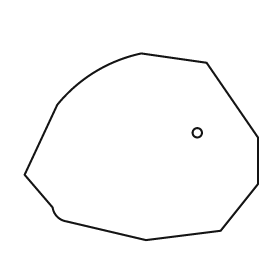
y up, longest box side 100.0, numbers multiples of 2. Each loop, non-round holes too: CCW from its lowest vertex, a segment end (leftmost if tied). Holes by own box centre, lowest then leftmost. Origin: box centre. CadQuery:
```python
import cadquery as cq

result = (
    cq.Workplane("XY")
    .moveTo(2.0, -40.0)
    .lineTo(34.0, -36.0)
    .lineTo(50.0, -16.0)
    .lineTo(50.0, 4.0)
    .lineTo(28.0, 36.0)
    .lineTo(0.0, 40.0)
    .threePointArc((-20.0, 32.0), (-36.0, 18.0))
    .lineTo(-50.0, -12.0)
    .lineTo(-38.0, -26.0)
    .threePointArc((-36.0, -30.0), (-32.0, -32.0))
    .close()
    .moveTo(24.0, 6.0)
    .circle(2.0)
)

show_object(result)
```